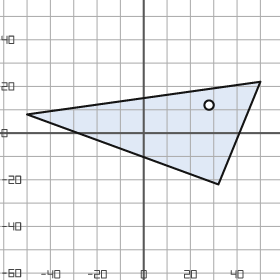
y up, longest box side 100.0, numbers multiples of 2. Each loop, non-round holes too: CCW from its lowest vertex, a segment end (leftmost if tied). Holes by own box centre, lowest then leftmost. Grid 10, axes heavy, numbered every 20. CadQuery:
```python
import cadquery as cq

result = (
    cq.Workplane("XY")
    .moveTo(32.0, -22.0)
    .lineTo(50.0, 22.0)
    .lineTo(-50.0, 8.0)
    .close()
    .moveTo(28.0, 12.0)
    .circle(2.0)
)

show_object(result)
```